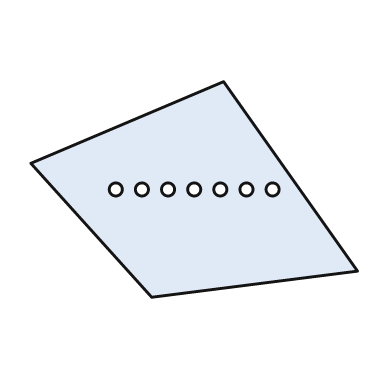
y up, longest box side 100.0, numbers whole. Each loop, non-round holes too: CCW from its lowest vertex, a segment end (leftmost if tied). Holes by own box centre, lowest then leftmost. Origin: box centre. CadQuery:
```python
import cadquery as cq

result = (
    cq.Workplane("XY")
    .moveTo(-13.0, -33.0)
    .lineTo(50.0, -25.0)
    .lineTo(9.0, 33.0)
    .lineTo(-50.0, 8.0)
    .close()
    .moveTo(-24.0, 0.0)
    .circle(2.0)
    .moveTo(-16.0, 0.0)
    .circle(2.0)
    .moveTo(-8.0, 0.0)
    .circle(2.0)
    .moveTo(0.0, 0.0)
    .circle(2.0)
    .moveTo(8.0, 0.0)
    .circle(2.0)
    .moveTo(16.0, 0.0)
    .circle(2.0)
    .moveTo(24.0, 0.0)
    .circle(2.0)
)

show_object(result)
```